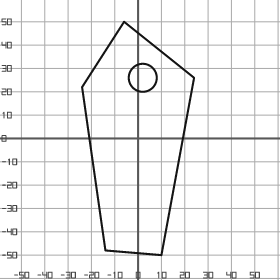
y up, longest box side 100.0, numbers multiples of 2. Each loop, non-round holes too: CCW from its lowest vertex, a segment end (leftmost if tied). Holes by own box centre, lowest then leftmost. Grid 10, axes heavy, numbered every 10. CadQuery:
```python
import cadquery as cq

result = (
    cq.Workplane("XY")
    .moveTo(10.0, -50.0)
    .lineTo(24.0, 26.0)
    .lineTo(-6.0, 50.0)
    .lineTo(-24.0, 22.0)
    .lineTo(-14.0, -48.0)
    .close()
    .moveTo(2.0, 26.0)
    .circle(6.0)
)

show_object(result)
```